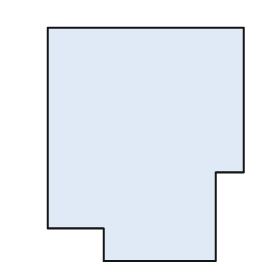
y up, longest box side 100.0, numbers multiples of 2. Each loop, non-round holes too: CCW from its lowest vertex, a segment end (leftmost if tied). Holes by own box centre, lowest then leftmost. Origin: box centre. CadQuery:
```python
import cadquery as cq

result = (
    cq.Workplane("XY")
    .moveTo(-18.0, -50.0)
    .lineTo(30.0, -50.0)
    .lineTo(30.0, -12.0)
    .lineTo(42.0, -12.0)
    .lineTo(42.0, 50.0)
    .lineTo(-42.0, 50.0)
    .lineTo(-42.0, -36.0)
    .lineTo(-18.0, -36.0)
    .close()
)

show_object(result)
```